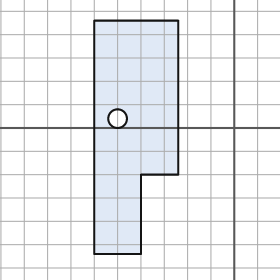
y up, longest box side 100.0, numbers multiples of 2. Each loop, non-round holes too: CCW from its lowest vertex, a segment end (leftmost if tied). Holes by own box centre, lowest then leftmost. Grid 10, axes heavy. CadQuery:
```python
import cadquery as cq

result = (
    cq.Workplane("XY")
    .moveTo(-60.0, -54.0)
    .lineTo(-40.0, -54.0)
    .lineTo(-40.0, -20.0)
    .lineTo(-24.0, -20.0)
    .lineTo(-24.0, 46.0)
    .lineTo(-60.0, 46.0)
    .close()
    .moveTo(-50.0, 4.0)
    .circle(4.0)
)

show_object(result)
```